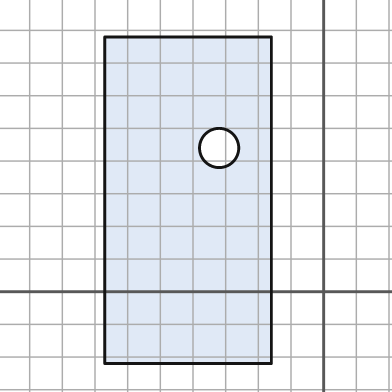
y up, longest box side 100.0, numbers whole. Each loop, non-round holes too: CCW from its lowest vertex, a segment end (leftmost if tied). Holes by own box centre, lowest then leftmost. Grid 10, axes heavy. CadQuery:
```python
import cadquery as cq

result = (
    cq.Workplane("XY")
    .moveTo(-67.0, -22.0)
    .lineTo(-16.0, -22.0)
    .lineTo(-16.0, 78.0)
    .lineTo(-67.0, 78.0)
    .close()
    .moveTo(-32.0, 44.0)
    .circle(6.0)
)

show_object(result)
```